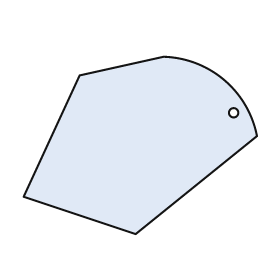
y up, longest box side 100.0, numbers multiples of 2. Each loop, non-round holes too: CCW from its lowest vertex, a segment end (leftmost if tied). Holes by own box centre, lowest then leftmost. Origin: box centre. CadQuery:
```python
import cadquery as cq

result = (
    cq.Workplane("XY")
    .moveTo(-2.0, -38.0)
    .lineTo(50.0, 4.0)
    .threePointArc((36.0, 28.0), (10.0, 38.0))
    .lineTo(-26.0, 30.0)
    .lineTo(-50.0, -22.0)
    .close()
    .moveTo(40.0, 14.0)
    .circle(2.0)
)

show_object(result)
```